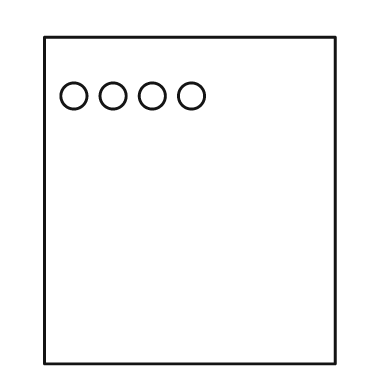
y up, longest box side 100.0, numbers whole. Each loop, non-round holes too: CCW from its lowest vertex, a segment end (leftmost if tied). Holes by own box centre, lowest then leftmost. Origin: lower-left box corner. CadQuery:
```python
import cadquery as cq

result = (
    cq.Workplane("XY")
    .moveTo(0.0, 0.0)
    .lineTo(89.0, 0.0)
    .lineTo(89.0, 100.0)
    .lineTo(0.0, 100.0)
    .close()
    .moveTo(9.0, 82.0)
    .circle(4.0)
    .moveTo(21.0, 82.0)
    .circle(4.0)
    .moveTo(33.0, 82.0)
    .circle(4.0)
    .moveTo(45.0, 82.0)
    .circle(4.0)
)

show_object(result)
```